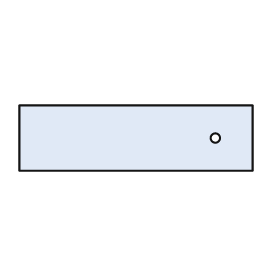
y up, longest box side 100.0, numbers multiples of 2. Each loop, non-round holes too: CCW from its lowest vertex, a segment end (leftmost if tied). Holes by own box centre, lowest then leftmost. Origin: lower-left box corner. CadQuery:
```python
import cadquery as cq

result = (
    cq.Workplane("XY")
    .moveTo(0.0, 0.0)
    .lineTo(100.0, 0.0)
    .lineTo(100.0, 28.0)
    .lineTo(0.0, 28.0)
    .close()
    .moveTo(84.0, 14.0)
    .circle(2.0)
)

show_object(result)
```